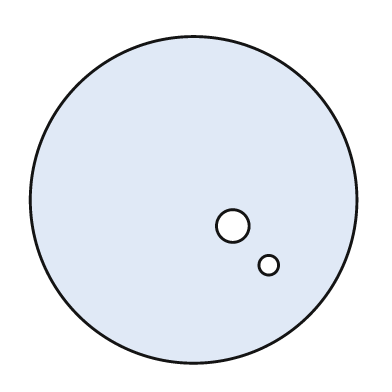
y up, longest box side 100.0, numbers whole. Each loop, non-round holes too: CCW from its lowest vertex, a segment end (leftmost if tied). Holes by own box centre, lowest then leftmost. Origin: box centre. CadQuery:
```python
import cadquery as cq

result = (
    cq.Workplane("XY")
    .moveTo(0.0, 0.0)
    .circle(50.0)
    .moveTo(23.0, -20.0)
    .circle(3.0)
    .moveTo(12.0, -8.0)
    .circle(5.0)
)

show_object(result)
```